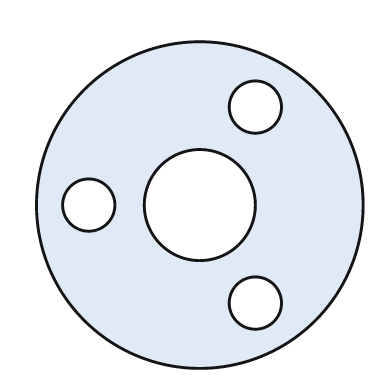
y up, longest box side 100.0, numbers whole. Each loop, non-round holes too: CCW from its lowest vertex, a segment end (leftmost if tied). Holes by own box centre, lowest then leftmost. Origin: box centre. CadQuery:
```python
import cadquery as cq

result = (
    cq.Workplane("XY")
    .moveTo(0.0, 0.0)
    .circle(50.0)
    .moveTo(17.0, -30.0)
    .circle(8.0)
    .moveTo(-34.0, 0.0)
    .circle(8.0)
    .moveTo(0.0, 0.0)
    .circle(17.0)
    .moveTo(17.0, 30.0)
    .circle(8.0)
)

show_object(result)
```